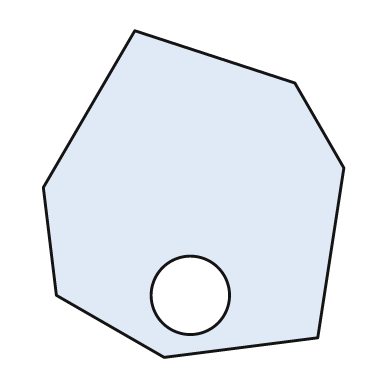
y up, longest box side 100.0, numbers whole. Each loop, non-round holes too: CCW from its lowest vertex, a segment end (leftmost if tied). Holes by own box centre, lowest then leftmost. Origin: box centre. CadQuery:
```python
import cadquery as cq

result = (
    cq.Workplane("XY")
    .moveTo(-9.0, -50.0)
    .lineTo(38.0, -44.0)
    .lineTo(46.0, 8.0)
    .lineTo(31.0, 34.0)
    .lineTo(-18.0, 50.0)
    .lineTo(-46.0, 2.0)
    .lineTo(-42.0, -31.0)
    .close()
    .moveTo(-1.0, -31.0)
    .circle(12.0)
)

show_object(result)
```